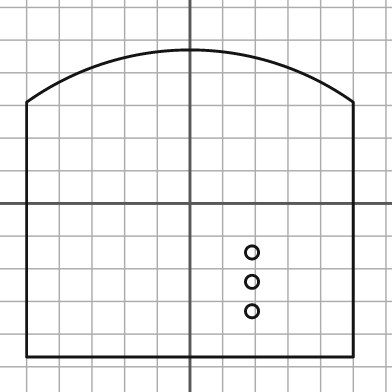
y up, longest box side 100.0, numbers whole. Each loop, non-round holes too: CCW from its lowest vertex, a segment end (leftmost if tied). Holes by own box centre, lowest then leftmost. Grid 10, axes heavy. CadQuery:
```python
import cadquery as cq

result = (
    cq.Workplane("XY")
    .moveTo(-50.0, -47.0)
    .lineTo(50.0, -47.0)
    .lineTo(50.0, 31.0)
    .threePointArc((0.0, 47.0), (-50.0, 31.0))
    .close()
    .moveTo(19.0, -33.0)
    .circle(2.0)
    .moveTo(19.0, -24.0)
    .circle(2.0)
    .moveTo(19.0, -15.0)
    .circle(2.0)
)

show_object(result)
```